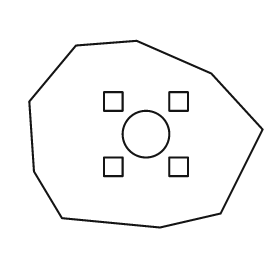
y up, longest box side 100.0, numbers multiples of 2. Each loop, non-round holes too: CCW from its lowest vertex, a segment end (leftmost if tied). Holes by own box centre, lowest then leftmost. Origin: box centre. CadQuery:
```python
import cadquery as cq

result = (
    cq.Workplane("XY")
    .moveTo(6.0, -40.0)
    .lineTo(32.0, -34.0)
    .lineTo(50.0, 2.0)
    .lineTo(28.0, 26.0)
    .lineTo(-4.0, 40.0)
    .lineTo(-30.0, 38.0)
    .lineTo(-50.0, 14.0)
    .lineTo(-48.0, -16.0)
    .lineTo(-36.0, -36.0)
    .close()
    .moveTo(-18.0, -18.0)
    .lineTo(-10.0, -18.0)
    .lineTo(-10.0, -10.0)
    .lineTo(-18.0, -10.0)
    .close()
    .moveTo(10.0, -18.0)
    .lineTo(18.0, -18.0)
    .lineTo(18.0, -10.0)
    .lineTo(10.0, -10.0)
    .close()
    .moveTo(0.0, 0.0)
    .circle(10.0)
    .moveTo(-18.0, 10.0)
    .lineTo(-10.0, 10.0)
    .lineTo(-10.0, 18.0)
    .lineTo(-18.0, 18.0)
    .close()
    .moveTo(10.0, 10.0)
    .lineTo(18.0, 10.0)
    .lineTo(18.0, 18.0)
    .lineTo(10.0, 18.0)
    .close()
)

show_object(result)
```